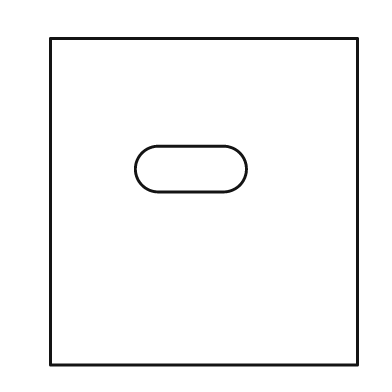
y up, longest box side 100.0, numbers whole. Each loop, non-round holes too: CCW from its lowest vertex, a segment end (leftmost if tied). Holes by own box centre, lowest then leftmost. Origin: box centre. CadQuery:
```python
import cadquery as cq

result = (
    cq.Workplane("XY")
    .moveTo(-47.0, -50.0)
    .lineTo(47.0, -50.0)
    .lineTo(47.0, 50.0)
    .lineTo(-47.0, 50.0)
    .close()
    .moveTo(-14.0, 3.0)
    .lineTo(6.0, 3.0)
    .threePointArc((13.0, 10.0), (6.0, 17.0))
    .lineTo(-14.0, 17.0)
    .threePointArc((-21.0, 10.0), (-14.0, 3.0))
    .close()
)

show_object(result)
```